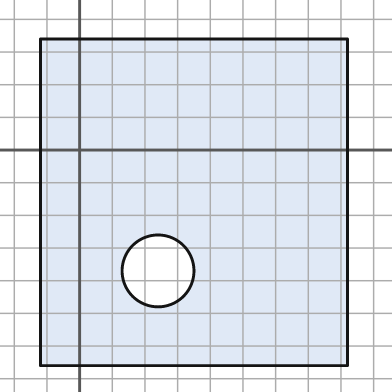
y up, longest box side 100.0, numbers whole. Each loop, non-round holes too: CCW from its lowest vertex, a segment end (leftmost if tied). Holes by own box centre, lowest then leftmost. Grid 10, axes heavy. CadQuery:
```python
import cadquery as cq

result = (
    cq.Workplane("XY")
    .moveTo(-12.0, -66.0)
    .lineTo(82.0, -66.0)
    .lineTo(82.0, 34.0)
    .lineTo(-12.0, 34.0)
    .close()
    .moveTo(24.0, -37.0)
    .circle(11.0)
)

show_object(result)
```